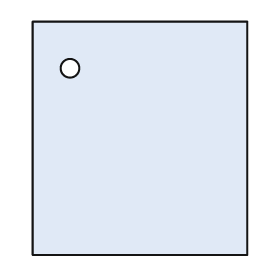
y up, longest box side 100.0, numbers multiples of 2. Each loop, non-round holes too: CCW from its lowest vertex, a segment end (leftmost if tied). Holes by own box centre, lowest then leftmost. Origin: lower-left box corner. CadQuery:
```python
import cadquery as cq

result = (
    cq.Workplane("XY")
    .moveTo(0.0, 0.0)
    .lineTo(92.0, 0.0)
    .lineTo(92.0, 100.0)
    .lineTo(0.0, 100.0)
    .close()
    .moveTo(16.0, 80.0)
    .circle(4.0)
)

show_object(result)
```